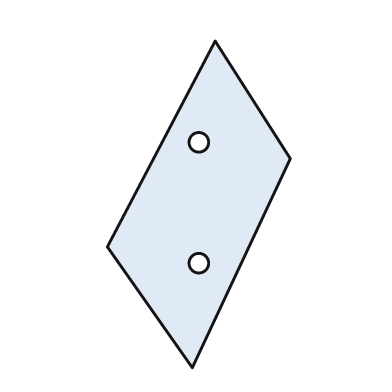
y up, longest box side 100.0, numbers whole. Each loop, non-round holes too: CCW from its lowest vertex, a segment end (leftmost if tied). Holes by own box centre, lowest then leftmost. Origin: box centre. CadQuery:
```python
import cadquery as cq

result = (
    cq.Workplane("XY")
    .moveTo(-2.0, -50.0)
    .lineTo(28.0, 14.0)
    .lineTo(5.0, 50.0)
    .lineTo(-28.0, -13.0)
    .close()
    .moveTo(0.0, -18.0)
    .circle(3.0)
    .moveTo(0.0, 19.0)
    .circle(3.0)
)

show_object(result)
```